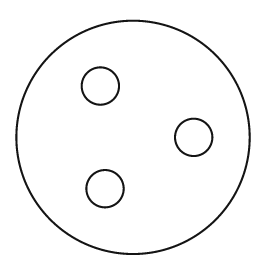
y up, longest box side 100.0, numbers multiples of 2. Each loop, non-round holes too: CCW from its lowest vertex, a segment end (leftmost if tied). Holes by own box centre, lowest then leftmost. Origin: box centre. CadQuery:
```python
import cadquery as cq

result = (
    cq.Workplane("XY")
    .moveTo(0.0, 0.0)
    .circle(50.0)
    .moveTo(-12.0, -22.0)
    .circle(8.0)
    .moveTo(26.0, 0.0)
    .circle(8.0)
    .moveTo(-14.0, 22.0)
    .circle(8.0)
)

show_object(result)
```